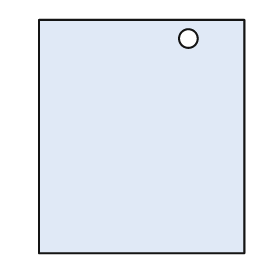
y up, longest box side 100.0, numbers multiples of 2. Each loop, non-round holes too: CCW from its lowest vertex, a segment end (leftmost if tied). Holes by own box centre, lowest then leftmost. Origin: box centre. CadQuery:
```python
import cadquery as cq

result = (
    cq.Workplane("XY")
    .moveTo(-44.0, -50.0)
    .lineTo(44.0, -50.0)
    .lineTo(44.0, 50.0)
    .lineTo(-44.0, 50.0)
    .close()
    .moveTo(20.0, 42.0)
    .circle(4.0)
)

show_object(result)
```